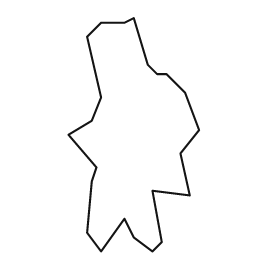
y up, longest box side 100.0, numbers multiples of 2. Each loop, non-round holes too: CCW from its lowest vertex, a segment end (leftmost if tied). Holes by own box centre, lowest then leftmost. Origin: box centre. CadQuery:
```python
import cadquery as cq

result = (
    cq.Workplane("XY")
    .moveTo(-14.0, -50.0)
    .lineTo(-4.0, -36.0)
    .lineTo(0.0, -44.0)
    .lineTo(8.0, -50.0)
    .lineTo(12.0, -46.0)
    .lineTo(8.0, -24.0)
    .lineTo(24.0, -26.0)
    .lineTo(20.0, -8.0)
    .lineTo(28.0, 2.0)
    .lineTo(22.0, 18.0)
    .lineTo(14.0, 26.0)
    .lineTo(10.0, 26.0)
    .lineTo(6.0, 30.0)
    .lineTo(0.0, 50.0)
    .lineTo(-4.0, 48.0)
    .lineTo(-14.0, 48.0)
    .lineTo(-20.0, 42.0)
    .lineTo(-14.0, 16.0)
    .lineTo(-18.0, 6.0)
    .lineTo(-28.0, 0.0)
    .lineTo(-16.0, -14.0)
    .lineTo(-18.0, -20.0)
    .lineTo(-20.0, -42.0)
    .close()
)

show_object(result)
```